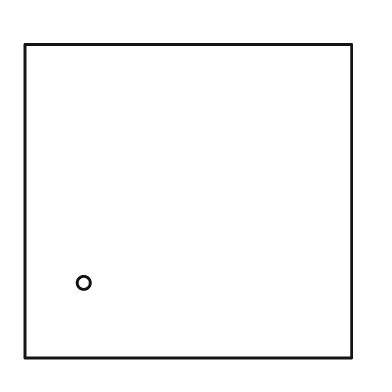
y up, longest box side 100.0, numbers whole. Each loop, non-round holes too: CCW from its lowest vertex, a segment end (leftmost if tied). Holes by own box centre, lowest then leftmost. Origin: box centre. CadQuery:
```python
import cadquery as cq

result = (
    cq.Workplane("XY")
    .moveTo(-50.0, -48.0)
    .lineTo(50.0, -48.0)
    .lineTo(50.0, 48.0)
    .lineTo(-50.0, 48.0)
    .close()
    .moveTo(-32.0, -25.0)
    .circle(2.0)
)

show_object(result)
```